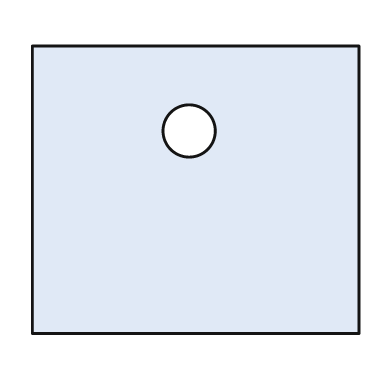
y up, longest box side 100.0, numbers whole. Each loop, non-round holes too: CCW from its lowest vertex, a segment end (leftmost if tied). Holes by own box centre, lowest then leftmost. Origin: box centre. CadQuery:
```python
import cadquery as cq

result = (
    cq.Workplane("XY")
    .moveTo(-50.0, -44.0)
    .lineTo(50.0, -44.0)
    .lineTo(50.0, 44.0)
    .lineTo(-50.0, 44.0)
    .close()
    .moveTo(-2.0, 18.0)
    .circle(8.0)
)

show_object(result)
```